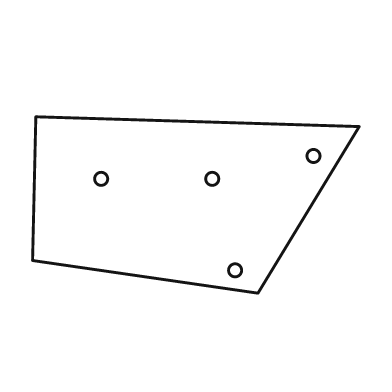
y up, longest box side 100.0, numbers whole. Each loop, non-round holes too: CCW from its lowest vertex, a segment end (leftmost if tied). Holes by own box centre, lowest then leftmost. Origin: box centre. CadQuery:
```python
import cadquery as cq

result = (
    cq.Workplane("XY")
    .moveTo(19.0, -27.0)
    .lineTo(50.0, 24.0)
    .lineTo(-49.0, 27.0)
    .lineTo(-50.0, -17.0)
    .close()
    .moveTo(12.0, -20.0)
    .circle(2.0)
    .moveTo(-29.0, 8.0)
    .circle(2.0)
    .moveTo(5.0, 8.0)
    .circle(2.0)
    .moveTo(36.0, 15.0)
    .circle(2.0)
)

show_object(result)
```